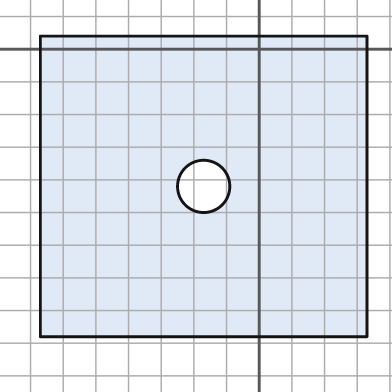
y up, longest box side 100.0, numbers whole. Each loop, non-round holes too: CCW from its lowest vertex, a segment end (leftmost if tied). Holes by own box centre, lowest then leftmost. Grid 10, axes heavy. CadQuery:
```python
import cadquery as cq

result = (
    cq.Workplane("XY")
    .moveTo(-67.0, -88.0)
    .lineTo(33.0, -88.0)
    .lineTo(33.0, 4.0)
    .lineTo(-67.0, 4.0)
    .close()
    .moveTo(-17.0, -42.0)
    .circle(8.0)
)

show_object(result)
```